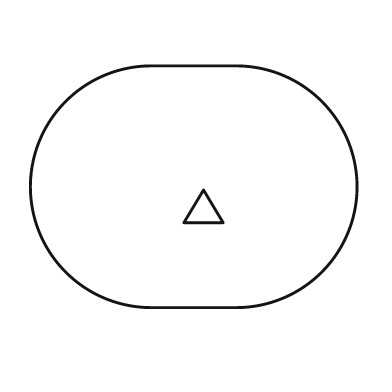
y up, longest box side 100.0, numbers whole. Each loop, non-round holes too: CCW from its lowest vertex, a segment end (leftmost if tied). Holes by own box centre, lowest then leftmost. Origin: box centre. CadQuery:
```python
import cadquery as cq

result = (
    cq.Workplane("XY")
    .moveTo(-13.0, -37.0)
    .lineTo(13.0, -37.0)
    .threePointArc((50.0, 0.0), (13.0, 37.0))
    .lineTo(-13.0, 37.0)
    .threePointArc((-50.0, 0.0), (-13.0, -37.0))
    .close()
    .moveTo(-3.0, -11.0)
    .lineTo(9.0, -11.0)
    .lineTo(3.0, -1.0)
    .close()
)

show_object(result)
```